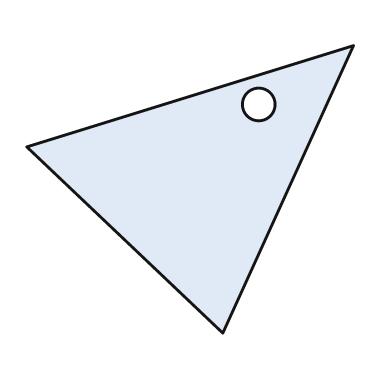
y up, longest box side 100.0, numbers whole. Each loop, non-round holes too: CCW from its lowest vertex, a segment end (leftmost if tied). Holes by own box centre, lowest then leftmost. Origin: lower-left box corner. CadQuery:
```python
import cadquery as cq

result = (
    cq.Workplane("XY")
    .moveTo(60.0, 0.0)
    .lineTo(100.0, 88.0)
    .lineTo(0.0, 57.0)
    .close()
    .moveTo(71.0, 70.0)
    .circle(5.0)
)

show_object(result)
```